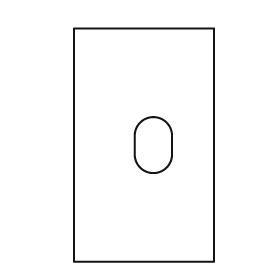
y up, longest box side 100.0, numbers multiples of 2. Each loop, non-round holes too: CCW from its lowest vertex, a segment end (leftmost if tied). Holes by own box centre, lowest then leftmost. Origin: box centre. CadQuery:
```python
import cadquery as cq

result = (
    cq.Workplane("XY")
    .moveTo(-30.0, -50.0)
    .lineTo(30.0, -50.0)
    .lineTo(30.0, 50.0)
    .lineTo(-30.0, 50.0)
    .close()
    .moveTo(-4.0, -4.0)
    .threePointArc((4.0, -12.0), (12.0, -4.0))
    .lineTo(12.0, 4.0)
    .threePointArc((4.0, 12.0), (-4.0, 4.0))
    .close()
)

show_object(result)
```